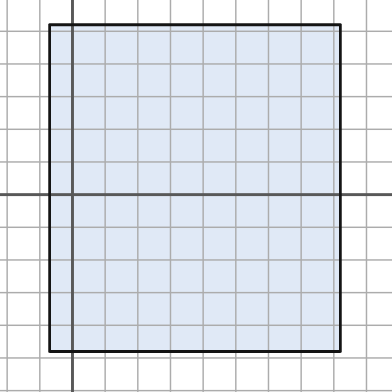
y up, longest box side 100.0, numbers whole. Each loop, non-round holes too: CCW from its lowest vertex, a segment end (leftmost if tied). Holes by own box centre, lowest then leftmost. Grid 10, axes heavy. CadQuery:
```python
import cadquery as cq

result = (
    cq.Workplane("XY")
    .moveTo(-7.0, -48.0)
    .lineTo(82.0, -48.0)
    .lineTo(82.0, 52.0)
    .lineTo(-7.0, 52.0)
    .close()
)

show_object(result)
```